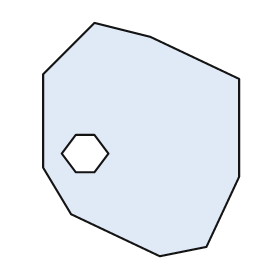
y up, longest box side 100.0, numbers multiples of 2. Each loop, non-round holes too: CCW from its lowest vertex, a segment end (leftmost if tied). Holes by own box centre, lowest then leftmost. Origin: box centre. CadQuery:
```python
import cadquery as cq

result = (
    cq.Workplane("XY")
    .moveTo(8.0, -50.0)
    .lineTo(28.0, -46.0)
    .lineTo(42.0, -16.0)
    .lineTo(42.0, 26.0)
    .lineTo(4.0, 44.0)
    .lineTo(-20.0, 50.0)
    .lineTo(-42.0, 28.0)
    .lineTo(-42.0, -12.0)
    .lineTo(-30.0, -32.0)
    .close()
    .moveTo(-28.0, -14.0)
    .lineTo(-20.0, -14.0)
    .lineTo(-14.0, -6.0)
    .lineTo(-20.0, 2.0)
    .lineTo(-28.0, 2.0)
    .lineTo(-34.0, -6.0)
    .close()
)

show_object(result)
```